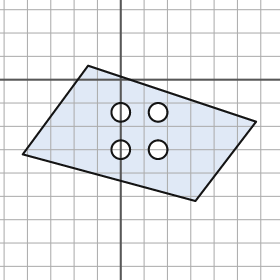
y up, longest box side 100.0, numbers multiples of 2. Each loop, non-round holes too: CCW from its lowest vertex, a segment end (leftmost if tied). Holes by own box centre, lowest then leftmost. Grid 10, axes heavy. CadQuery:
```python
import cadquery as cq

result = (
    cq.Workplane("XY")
    .moveTo(32.0, -52.0)
    .lineTo(58.0, -18.0)
    .lineTo(-14.0, 6.0)
    .lineTo(-42.0, -32.0)
    .close()
    .moveTo(0.0, -30.0)
    .circle(4.0)
    .moveTo(16.0, -30.0)
    .circle(4.0)
    .moveTo(0.0, -14.0)
    .circle(4.0)
    .moveTo(16.0, -14.0)
    .circle(4.0)
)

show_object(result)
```